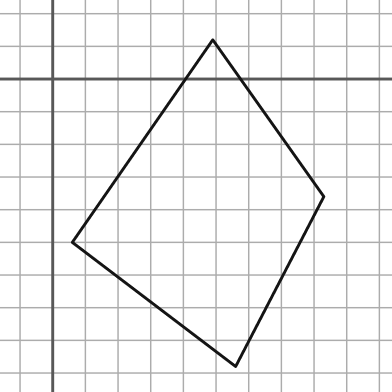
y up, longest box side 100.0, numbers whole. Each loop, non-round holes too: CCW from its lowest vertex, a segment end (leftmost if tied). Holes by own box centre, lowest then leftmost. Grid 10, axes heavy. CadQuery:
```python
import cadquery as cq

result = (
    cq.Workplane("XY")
    .moveTo(56.0, -88.0)
    .lineTo(83.0, -36.0)
    .lineTo(49.0, 12.0)
    .lineTo(6.0, -50.0)
    .close()
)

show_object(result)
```